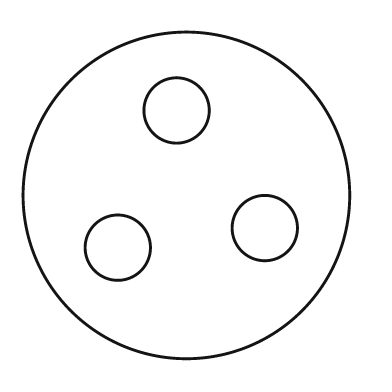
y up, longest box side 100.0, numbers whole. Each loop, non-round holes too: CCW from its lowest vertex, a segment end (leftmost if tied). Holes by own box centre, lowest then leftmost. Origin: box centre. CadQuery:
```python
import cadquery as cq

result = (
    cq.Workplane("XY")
    .moveTo(0.0, 0.0)
    .circle(50.0)
    .moveTo(-21.0, -16.0)
    .circle(10.0)
    .moveTo(24.0, -10.0)
    .circle(10.0)
    .moveTo(-3.0, 26.0)
    .circle(10.0)
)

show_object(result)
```